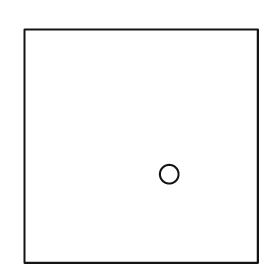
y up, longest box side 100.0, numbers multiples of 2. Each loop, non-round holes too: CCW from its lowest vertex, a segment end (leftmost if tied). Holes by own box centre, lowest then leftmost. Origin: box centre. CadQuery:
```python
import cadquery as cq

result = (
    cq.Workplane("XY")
    .moveTo(-50.0, -50.0)
    .lineTo(50.0, -50.0)
    .lineTo(50.0, 50.0)
    .lineTo(-50.0, 50.0)
    .close()
    .moveTo(12.0, -12.0)
    .circle(4.0)
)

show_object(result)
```